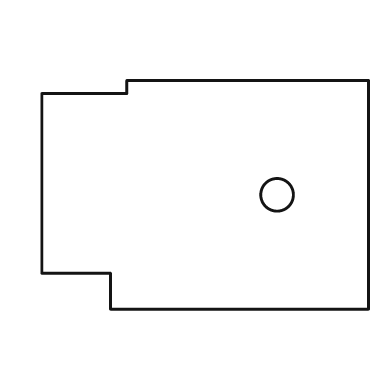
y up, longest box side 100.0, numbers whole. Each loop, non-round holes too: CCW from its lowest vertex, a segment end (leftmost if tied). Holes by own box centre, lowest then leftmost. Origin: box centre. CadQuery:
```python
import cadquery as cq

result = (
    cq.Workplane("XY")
    .moveTo(-29.0, -35.0)
    .lineTo(50.0, -35.0)
    .lineTo(50.0, 35.0)
    .lineTo(-24.0, 35.0)
    .lineTo(-24.0, 31.0)
    .lineTo(-50.0, 31.0)
    .lineTo(-50.0, -24.0)
    .lineTo(-29.0, -24.0)
    .close()
    .moveTo(22.0, 0.0)
    .circle(5.0)
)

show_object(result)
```